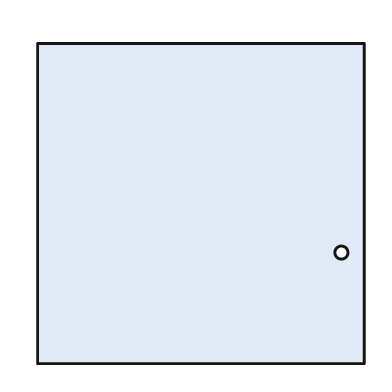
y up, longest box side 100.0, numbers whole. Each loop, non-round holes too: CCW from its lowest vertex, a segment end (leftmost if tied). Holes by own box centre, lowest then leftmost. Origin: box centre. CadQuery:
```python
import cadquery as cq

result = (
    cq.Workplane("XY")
    .moveTo(-50.0, -49.0)
    .lineTo(50.0, -49.0)
    .lineTo(50.0, 49.0)
    .lineTo(-50.0, 49.0)
    .close()
    .moveTo(43.0, -15.0)
    .circle(2.0)
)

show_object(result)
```